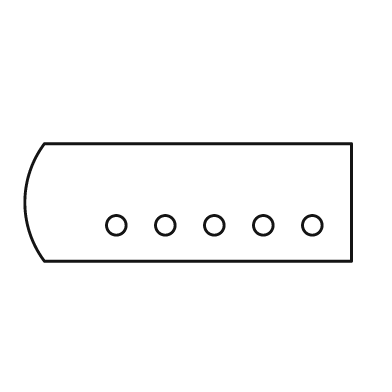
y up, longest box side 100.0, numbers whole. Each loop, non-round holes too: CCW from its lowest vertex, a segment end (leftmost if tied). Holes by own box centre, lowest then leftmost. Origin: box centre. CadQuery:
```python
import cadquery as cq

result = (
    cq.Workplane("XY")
    .moveTo(-44.0, -18.0)
    .lineTo(50.0, -18.0)
    .lineTo(50.0, 18.0)
    .lineTo(-44.0, 18.0)
    .threePointArc((-50.0, 0.0), (-44.0, -18.0))
    .close()
    .moveTo(-22.0, -7.0)
    .circle(3.0)
    .moveTo(-7.0, -7.0)
    .circle(3.0)
    .moveTo(8.0, -7.0)
    .circle(3.0)
    .moveTo(23.0, -7.0)
    .circle(3.0)
    .moveTo(38.0, -7.0)
    .circle(3.0)
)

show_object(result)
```